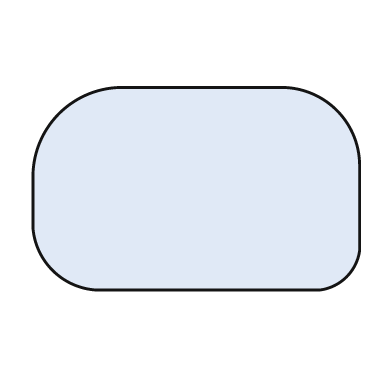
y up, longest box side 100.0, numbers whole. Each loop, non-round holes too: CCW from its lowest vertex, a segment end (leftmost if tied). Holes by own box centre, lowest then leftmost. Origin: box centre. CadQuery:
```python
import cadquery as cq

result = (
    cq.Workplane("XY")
    .moveTo(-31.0, -31.0)
    .lineTo(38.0, -31.0)
    .threePointArc((46.0, -27.0), (50.0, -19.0))
    .lineTo(50.0, 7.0)
    .threePointArc((43.0, 24.0), (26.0, 31.0))
    .lineTo(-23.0, 31.0)
    .threePointArc((-42.0, 23.0), (-50.0, 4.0))
    .lineTo(-50.0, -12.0)
    .threePointArc((-44.0, -25.0), (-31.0, -31.0))
    .close()
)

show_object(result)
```